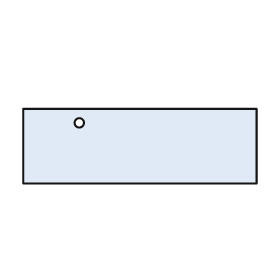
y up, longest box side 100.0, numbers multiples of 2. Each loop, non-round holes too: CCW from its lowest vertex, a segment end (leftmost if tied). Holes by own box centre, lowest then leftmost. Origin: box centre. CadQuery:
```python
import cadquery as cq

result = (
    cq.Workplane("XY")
    .moveTo(-50.0, -16.0)
    .lineTo(50.0, -16.0)
    .lineTo(50.0, 16.0)
    .lineTo(-50.0, 16.0)
    .close()
    .moveTo(-26.0, 10.0)
    .circle(2.0)
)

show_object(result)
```